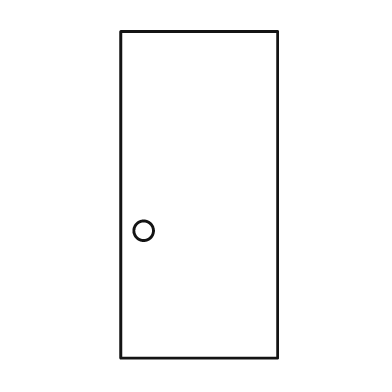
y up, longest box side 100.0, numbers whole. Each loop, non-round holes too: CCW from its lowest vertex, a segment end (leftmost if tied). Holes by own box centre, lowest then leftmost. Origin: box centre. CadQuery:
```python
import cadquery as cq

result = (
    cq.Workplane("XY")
    .moveTo(-24.0, -50.0)
    .lineTo(24.0, -50.0)
    .lineTo(24.0, 50.0)
    .lineTo(-24.0, 50.0)
    .close()
    .moveTo(-17.0, -11.0)
    .circle(3.0)
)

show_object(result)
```